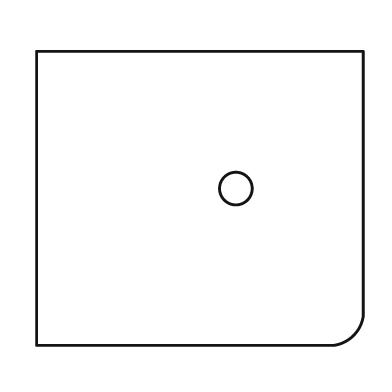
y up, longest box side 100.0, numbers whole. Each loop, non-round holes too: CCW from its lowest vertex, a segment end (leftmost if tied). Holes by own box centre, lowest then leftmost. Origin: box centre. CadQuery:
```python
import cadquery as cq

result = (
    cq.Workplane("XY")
    .moveTo(-50.0, -45.0)
    .lineTo(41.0, -45.0)
    .threePointArc((47.0, -42.0), (50.0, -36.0))
    .lineTo(50.0, 45.0)
    .lineTo(-50.0, 45.0)
    .close()
    .moveTo(11.0, 3.0)
    .circle(5.0)
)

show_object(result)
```